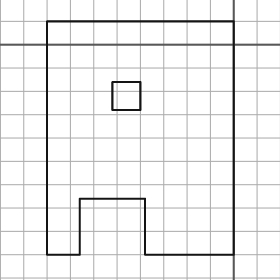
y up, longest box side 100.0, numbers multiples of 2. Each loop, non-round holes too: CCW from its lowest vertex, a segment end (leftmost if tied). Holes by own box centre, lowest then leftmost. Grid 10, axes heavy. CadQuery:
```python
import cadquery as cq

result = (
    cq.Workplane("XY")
    .moveTo(-80.0, -90.0)
    .lineTo(-66.0, -90.0)
    .lineTo(-66.0, -66.0)
    .lineTo(-38.0, -66.0)
    .lineTo(-38.0, -90.0)
    .lineTo(0.0, -90.0)
    .lineTo(0.0, 10.0)
    .lineTo(-80.0, 10.0)
    .close()
    .moveTo(-52.0, -28.0)
    .lineTo(-40.0, -28.0)
    .lineTo(-40.0, -16.0)
    .lineTo(-52.0, -16.0)
    .close()
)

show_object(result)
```